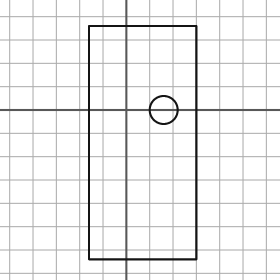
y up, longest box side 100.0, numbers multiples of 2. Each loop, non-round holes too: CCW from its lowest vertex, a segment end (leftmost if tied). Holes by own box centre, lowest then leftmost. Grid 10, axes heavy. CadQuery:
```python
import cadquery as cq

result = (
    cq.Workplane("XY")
    .moveTo(-16.0, -64.0)
    .lineTo(30.0, -64.0)
    .lineTo(30.0, 36.0)
    .lineTo(-16.0, 36.0)
    .close()
    .moveTo(16.0, 0.0)
    .circle(6.0)
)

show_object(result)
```